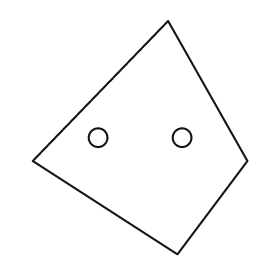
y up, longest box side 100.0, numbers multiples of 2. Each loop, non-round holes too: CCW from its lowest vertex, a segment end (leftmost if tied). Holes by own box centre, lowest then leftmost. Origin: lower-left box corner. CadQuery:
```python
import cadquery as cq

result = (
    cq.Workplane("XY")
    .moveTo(62.0, 0.0)
    .lineTo(92.0, 40.0)
    .lineTo(58.0, 100.0)
    .lineTo(0.0, 40.0)
    .close()
    .moveTo(28.0, 50.0)
    .circle(4.0)
    .moveTo(64.0, 50.0)
    .circle(4.0)
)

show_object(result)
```